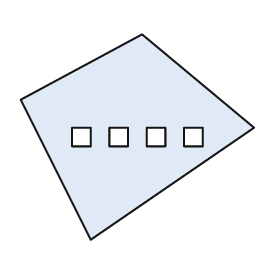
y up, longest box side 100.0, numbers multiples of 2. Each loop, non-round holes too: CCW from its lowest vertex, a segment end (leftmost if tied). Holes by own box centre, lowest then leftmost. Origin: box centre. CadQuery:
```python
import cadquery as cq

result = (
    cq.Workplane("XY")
    .moveTo(-20.0, -44.0)
    .lineTo(50.0, 4.0)
    .lineTo(2.0, 44.0)
    .lineTo(-50.0, 16.0)
    .close()
    .moveTo(-28.0, -4.0)
    .lineTo(-20.0, -4.0)
    .lineTo(-20.0, 4.0)
    .lineTo(-28.0, 4.0)
    .close()
    .moveTo(-12.0, -4.0)
    .lineTo(-4.0, -4.0)
    .lineTo(-4.0, 4.0)
    .lineTo(-12.0, 4.0)
    .close()
    .moveTo(4.0, -4.0)
    .lineTo(12.0, -4.0)
    .lineTo(12.0, 4.0)
    .lineTo(4.0, 4.0)
    .close()
    .moveTo(20.0, -4.0)
    .lineTo(28.0, -4.0)
    .lineTo(28.0, 4.0)
    .lineTo(20.0, 4.0)
    .close()
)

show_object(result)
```